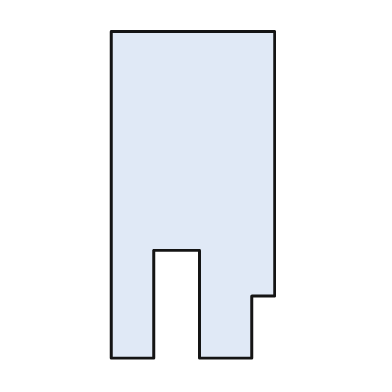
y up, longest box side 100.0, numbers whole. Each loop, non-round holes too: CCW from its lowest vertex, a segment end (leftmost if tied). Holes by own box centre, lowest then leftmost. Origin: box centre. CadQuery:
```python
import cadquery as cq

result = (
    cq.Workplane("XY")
    .moveTo(-25.0, -50.0)
    .lineTo(-12.0, -50.0)
    .lineTo(-12.0, -17.0)
    .lineTo(2.0, -17.0)
    .lineTo(2.0, -50.0)
    .lineTo(18.0, -50.0)
    .lineTo(18.0, -31.0)
    .lineTo(25.0, -31.0)
    .lineTo(25.0, 50.0)
    .lineTo(-25.0, 50.0)
    .close()
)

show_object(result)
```